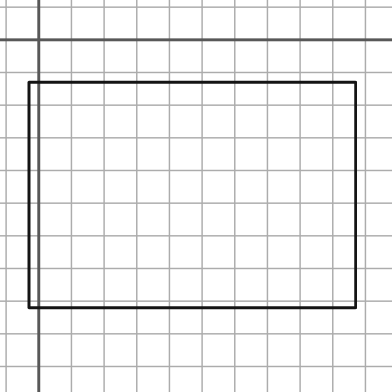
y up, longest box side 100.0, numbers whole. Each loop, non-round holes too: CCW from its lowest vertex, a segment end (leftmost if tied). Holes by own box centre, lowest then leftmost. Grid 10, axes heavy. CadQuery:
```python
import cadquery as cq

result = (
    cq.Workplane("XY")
    .moveTo(-3.0, -82.0)
    .lineTo(97.0, -82.0)
    .lineTo(97.0, -13.0)
    .lineTo(-3.0, -13.0)
    .close()
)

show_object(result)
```